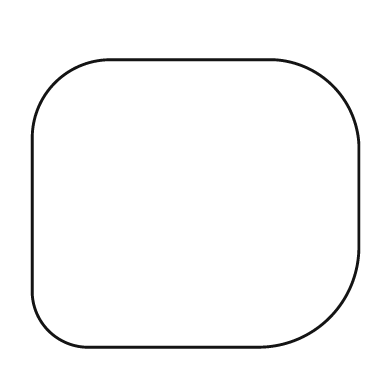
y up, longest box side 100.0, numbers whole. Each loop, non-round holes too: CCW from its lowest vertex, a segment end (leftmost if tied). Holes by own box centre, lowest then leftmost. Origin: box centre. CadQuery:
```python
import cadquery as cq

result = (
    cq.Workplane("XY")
    .moveTo(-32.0, -44.0)
    .lineTo(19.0, -44.0)
    .threePointArc((41.0, -35.0), (50.0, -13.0))
    .lineTo(50.0, 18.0)
    .threePointArc((42.0, 36.0), (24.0, 44.0))
    .lineTo(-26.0, 44.0)
    .threePointArc((-43.0, 37.0), (-50.0, 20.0))
    .lineTo(-50.0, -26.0)
    .threePointArc((-45.0, -39.0), (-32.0, -44.0))
    .close()
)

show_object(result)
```